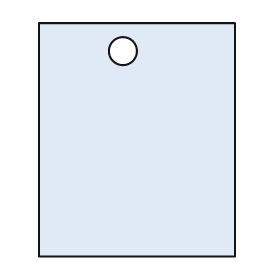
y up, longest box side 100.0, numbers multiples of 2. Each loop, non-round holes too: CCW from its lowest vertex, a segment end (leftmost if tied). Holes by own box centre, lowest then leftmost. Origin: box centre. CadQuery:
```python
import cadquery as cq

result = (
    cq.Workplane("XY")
    .moveTo(-42.0, -50.0)
    .lineTo(42.0, -50.0)
    .lineTo(42.0, 50.0)
    .lineTo(-42.0, 50.0)
    .close()
    .moveTo(-6.0, 38.0)
    .circle(6.0)
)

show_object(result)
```